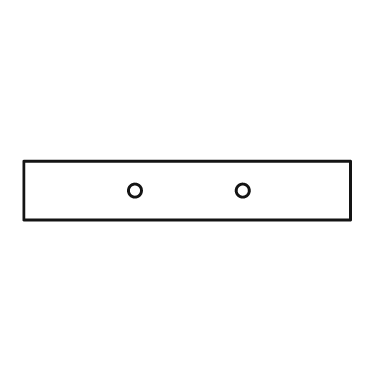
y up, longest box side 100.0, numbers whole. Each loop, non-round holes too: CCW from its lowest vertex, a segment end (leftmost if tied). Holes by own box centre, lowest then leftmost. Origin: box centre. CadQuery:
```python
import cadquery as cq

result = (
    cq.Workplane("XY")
    .moveTo(-50.0, -9.0)
    .lineTo(50.0, -9.0)
    .lineTo(50.0, 9.0)
    .lineTo(-50.0, 9.0)
    .close()
    .moveTo(-16.0, 0.0)
    .circle(2.0)
    .moveTo(17.0, 0.0)
    .circle(2.0)
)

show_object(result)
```